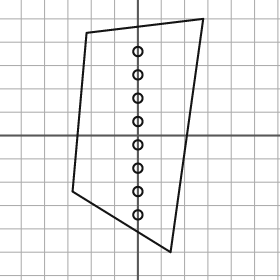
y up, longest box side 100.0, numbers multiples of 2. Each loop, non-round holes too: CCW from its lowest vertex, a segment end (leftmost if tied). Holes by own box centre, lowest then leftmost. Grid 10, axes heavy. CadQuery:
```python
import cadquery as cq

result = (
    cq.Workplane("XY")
    .moveTo(14.0, -50.0)
    .lineTo(28.0, 50.0)
    .lineTo(-22.0, 44.0)
    .lineTo(-28.0, -24.0)
    .close()
    .moveTo(0.0, -34.0)
    .circle(2.0)
    .moveTo(0.0, -24.0)
    .circle(2.0)
    .moveTo(0.0, -14.0)
    .circle(2.0)
    .moveTo(0.0, -4.0)
    .circle(2.0)
    .moveTo(0.0, 6.0)
    .circle(2.0)
    .moveTo(0.0, 16.0)
    .circle(2.0)
    .moveTo(0.0, 26.0)
    .circle(2.0)
    .moveTo(0.0, 36.0)
    .circle(2.0)
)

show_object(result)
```